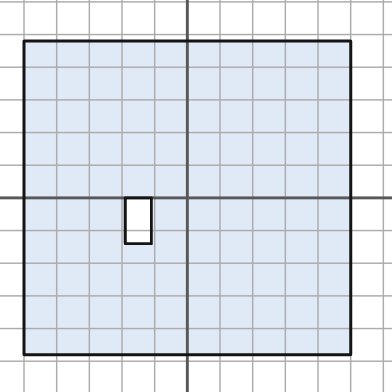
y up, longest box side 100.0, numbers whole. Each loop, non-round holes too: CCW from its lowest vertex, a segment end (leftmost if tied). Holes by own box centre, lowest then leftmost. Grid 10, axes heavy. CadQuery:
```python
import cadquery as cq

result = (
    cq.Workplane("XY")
    .moveTo(-50.0, -48.0)
    .lineTo(50.0, -48.0)
    .lineTo(50.0, 48.0)
    .lineTo(-50.0, 48.0)
    .close()
    .moveTo(-19.0, -14.0)
    .lineTo(-11.0, -14.0)
    .lineTo(-11.0, 0.0)
    .lineTo(-19.0, 0.0)
    .close()
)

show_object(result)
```